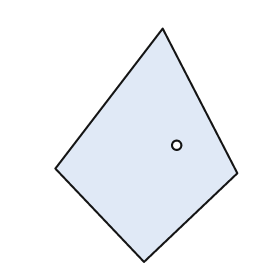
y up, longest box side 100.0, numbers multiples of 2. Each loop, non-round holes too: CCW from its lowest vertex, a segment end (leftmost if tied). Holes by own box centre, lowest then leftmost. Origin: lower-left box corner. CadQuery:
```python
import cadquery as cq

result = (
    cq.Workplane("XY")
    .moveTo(38.0, 0.0)
    .lineTo(78.0, 38.0)
    .lineTo(46.0, 100.0)
    .lineTo(0.0, 40.0)
    .close()
    .moveTo(52.0, 50.0)
    .circle(2.0)
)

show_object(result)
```